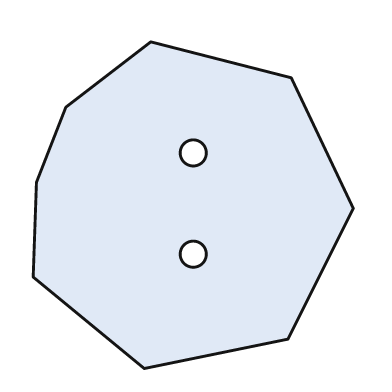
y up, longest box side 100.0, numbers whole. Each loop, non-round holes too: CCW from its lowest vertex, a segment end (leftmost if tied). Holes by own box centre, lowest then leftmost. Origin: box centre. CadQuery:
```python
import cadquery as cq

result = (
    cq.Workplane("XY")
    .moveTo(-15.0, -50.0)
    .lineTo(29.0, -41.0)
    .lineTo(49.0, -1.0)
    .lineTo(30.0, 39.0)
    .lineTo(-13.0, 50.0)
    .lineTo(-39.0, 30.0)
    .lineTo(-48.0, 7.0)
    .lineTo(-49.0, -22.0)
    .close()
    .moveTo(0.0, -15.0)
    .circle(4.0)
    .moveTo(0.0, 16.0)
    .circle(4.0)
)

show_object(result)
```